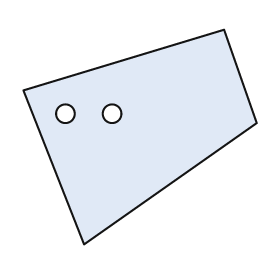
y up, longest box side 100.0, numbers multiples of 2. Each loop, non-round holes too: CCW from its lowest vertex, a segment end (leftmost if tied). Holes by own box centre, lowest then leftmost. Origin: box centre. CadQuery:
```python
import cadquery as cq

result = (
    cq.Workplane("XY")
    .moveTo(-24.0, -46.0)
    .lineTo(50.0, 6.0)
    .lineTo(36.0, 46.0)
    .lineTo(-50.0, 20.0)
    .close()
    .moveTo(-32.0, 10.0)
    .circle(4.0)
    .moveTo(-12.0, 10.0)
    .circle(4.0)
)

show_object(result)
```